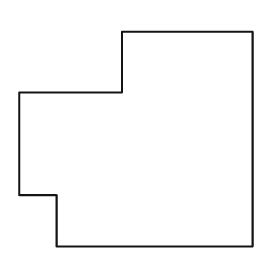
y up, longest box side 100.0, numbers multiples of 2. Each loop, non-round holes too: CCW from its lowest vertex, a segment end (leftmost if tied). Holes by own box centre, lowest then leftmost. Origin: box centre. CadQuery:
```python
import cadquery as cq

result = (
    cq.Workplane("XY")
    .moveTo(-34.0, -46.0)
    .lineTo(50.0, -46.0)
    .lineTo(50.0, 46.0)
    .lineTo(-6.0, 46.0)
    .lineTo(-6.0, 20.0)
    .lineTo(-50.0, 20.0)
    .lineTo(-50.0, -24.0)
    .lineTo(-34.0, -24.0)
    .close()
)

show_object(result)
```